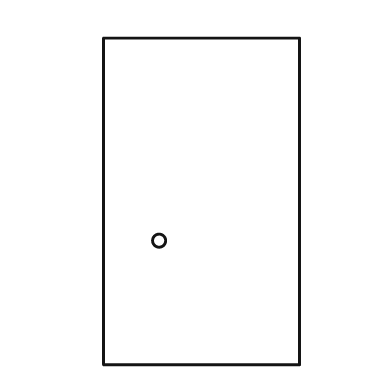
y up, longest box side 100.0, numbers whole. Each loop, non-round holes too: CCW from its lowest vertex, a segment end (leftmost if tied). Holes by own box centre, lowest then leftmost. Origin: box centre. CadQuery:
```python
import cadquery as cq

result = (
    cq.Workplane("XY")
    .moveTo(-30.0, -50.0)
    .lineTo(30.0, -50.0)
    .lineTo(30.0, 50.0)
    .lineTo(-30.0, 50.0)
    .close()
    .moveTo(-13.0, -12.0)
    .circle(2.0)
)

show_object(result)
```